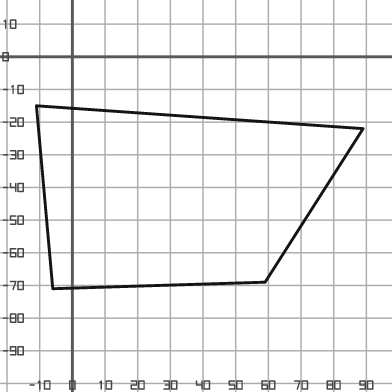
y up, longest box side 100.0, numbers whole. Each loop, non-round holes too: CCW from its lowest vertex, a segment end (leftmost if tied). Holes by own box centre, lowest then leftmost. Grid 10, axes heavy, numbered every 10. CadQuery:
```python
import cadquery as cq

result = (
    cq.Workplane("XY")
    .moveTo(-6.0, -71.0)
    .lineTo(59.0, -69.0)
    .lineTo(89.0, -22.0)
    .lineTo(-11.0, -15.0)
    .close()
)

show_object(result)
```